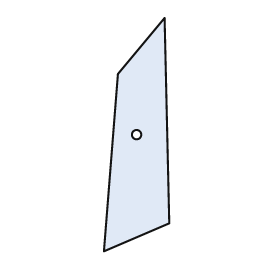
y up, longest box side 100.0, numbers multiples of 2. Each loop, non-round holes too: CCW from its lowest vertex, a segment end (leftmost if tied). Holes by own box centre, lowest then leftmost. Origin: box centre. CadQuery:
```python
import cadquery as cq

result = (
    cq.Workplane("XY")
    .moveTo(-14.0, -50.0)
    .lineTo(14.0, -38.0)
    .lineTo(12.0, 50.0)
    .lineTo(-8.0, 26.0)
    .close()
    .moveTo(0.0, 0.0)
    .circle(2.0)
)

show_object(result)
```